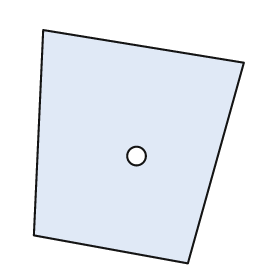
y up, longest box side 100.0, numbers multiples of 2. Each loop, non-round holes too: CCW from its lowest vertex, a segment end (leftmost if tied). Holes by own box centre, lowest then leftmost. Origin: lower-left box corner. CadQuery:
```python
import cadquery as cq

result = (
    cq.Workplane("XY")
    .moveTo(66.0, 0.0)
    .lineTo(90.0, 86.0)
    .lineTo(4.0, 100.0)
    .lineTo(0.0, 12.0)
    .close()
    .moveTo(44.0, 46.0)
    .circle(4.0)
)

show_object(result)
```